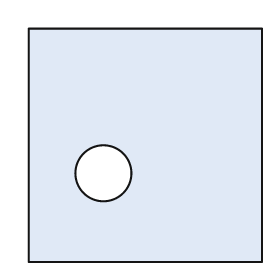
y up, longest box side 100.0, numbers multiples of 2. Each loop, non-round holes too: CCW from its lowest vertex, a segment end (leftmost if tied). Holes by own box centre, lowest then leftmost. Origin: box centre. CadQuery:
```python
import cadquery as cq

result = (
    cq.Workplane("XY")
    .moveTo(-50.0, -50.0)
    .lineTo(50.0, -50.0)
    .lineTo(50.0, 50.0)
    .lineTo(-50.0, 50.0)
    .close()
    .moveTo(-18.0, -12.0)
    .circle(12.0)
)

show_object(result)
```